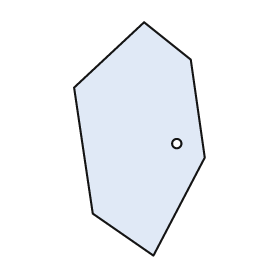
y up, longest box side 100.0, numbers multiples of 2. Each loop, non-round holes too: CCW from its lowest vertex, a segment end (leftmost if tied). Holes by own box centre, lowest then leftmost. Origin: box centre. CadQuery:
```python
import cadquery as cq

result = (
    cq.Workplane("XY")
    .moveTo(6.0, -50.0)
    .lineTo(28.0, -8.0)
    .lineTo(22.0, 34.0)
    .lineTo(2.0, 50.0)
    .lineTo(-28.0, 22.0)
    .lineTo(-20.0, -32.0)
    .close()
    .moveTo(16.0, -2.0)
    .circle(2.0)
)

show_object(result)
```